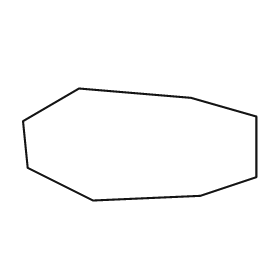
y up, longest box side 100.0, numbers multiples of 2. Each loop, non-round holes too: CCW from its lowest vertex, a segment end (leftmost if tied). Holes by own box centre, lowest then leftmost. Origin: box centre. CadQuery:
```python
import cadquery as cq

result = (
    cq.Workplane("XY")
    .moveTo(-20.0, -24.0)
    .lineTo(26.0, -22.0)
    .lineTo(50.0, -14.0)
    .lineTo(50.0, 12.0)
    .lineTo(22.0, 20.0)
    .lineTo(-26.0, 24.0)
    .lineTo(-50.0, 10.0)
    .lineTo(-48.0, -10.0)
    .close()
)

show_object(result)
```